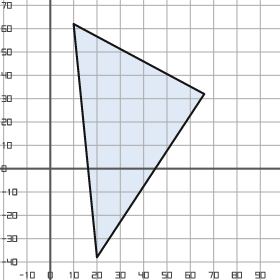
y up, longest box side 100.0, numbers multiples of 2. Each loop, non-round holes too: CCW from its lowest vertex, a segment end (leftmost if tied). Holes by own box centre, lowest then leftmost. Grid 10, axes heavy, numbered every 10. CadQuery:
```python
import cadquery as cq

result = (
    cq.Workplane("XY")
    .moveTo(20.0, -38.0)
    .lineTo(66.0, 32.0)
    .lineTo(10.0, 62.0)
    .close()
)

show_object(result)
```